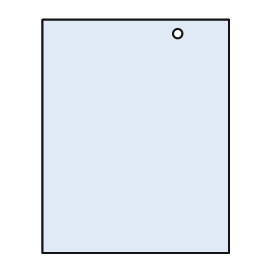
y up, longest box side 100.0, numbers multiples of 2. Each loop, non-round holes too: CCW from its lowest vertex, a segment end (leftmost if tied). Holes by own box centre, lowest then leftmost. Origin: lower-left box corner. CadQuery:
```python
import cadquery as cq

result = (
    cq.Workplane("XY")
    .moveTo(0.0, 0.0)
    .lineTo(80.0, 0.0)
    .lineTo(80.0, 100.0)
    .lineTo(0.0, 100.0)
    .close()
    .moveTo(58.0, 94.0)
    .circle(2.0)
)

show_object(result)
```